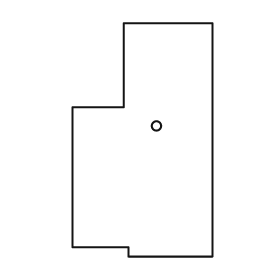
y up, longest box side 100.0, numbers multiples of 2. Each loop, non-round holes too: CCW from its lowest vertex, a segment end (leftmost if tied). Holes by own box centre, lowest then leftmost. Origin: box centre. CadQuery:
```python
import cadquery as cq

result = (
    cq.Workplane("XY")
    .moveTo(-6.0, -50.0)
    .lineTo(30.0, -50.0)
    .lineTo(30.0, 50.0)
    .lineTo(-8.0, 50.0)
    .lineTo(-8.0, 14.0)
    .lineTo(-30.0, 14.0)
    .lineTo(-30.0, -46.0)
    .lineTo(-6.0, -46.0)
    .close()
    .moveTo(6.0, 6.0)
    .circle(2.0)
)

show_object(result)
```